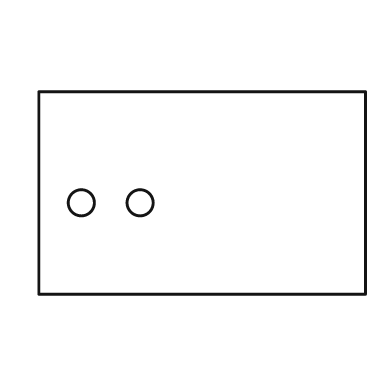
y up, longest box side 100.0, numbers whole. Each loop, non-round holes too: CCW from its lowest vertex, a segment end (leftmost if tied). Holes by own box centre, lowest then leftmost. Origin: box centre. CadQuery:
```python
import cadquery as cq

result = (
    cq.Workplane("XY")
    .moveTo(-50.0, -31.0)
    .lineTo(50.0, -31.0)
    .lineTo(50.0, 31.0)
    .lineTo(-50.0, 31.0)
    .close()
    .moveTo(-37.0, -3.0)
    .circle(4.0)
    .moveTo(-19.0, -3.0)
    .circle(4.0)
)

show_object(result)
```